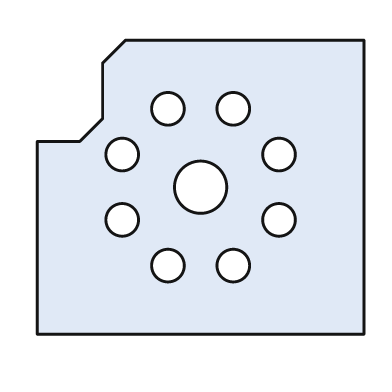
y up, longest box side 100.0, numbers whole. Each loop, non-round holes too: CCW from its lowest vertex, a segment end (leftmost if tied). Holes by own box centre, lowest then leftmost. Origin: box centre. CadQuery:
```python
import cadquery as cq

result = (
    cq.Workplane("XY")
    .moveTo(-50.0, -45.0)
    .lineTo(50.0, -45.0)
    .lineTo(50.0, 45.0)
    .lineTo(-23.0, 45.0)
    .lineTo(-30.0, 38.0)
    .lineTo(-30.0, 21.0)
    .lineTo(-37.0, 14.0)
    .lineTo(-50.0, 14.0)
    .close()
    .moveTo(-10.0, -24.0)
    .circle(5.0)
    .moveTo(10.0, -24.0)
    .circle(5.0)
    .moveTo(-24.0, -10.0)
    .circle(5.0)
    .moveTo(24.0, -10.0)
    .circle(5.0)
    .moveTo(0.0, 0.0)
    .circle(8.0)
    .moveTo(-24.0, 10.0)
    .circle(5.0)
    .moveTo(24.0, 10.0)
    .circle(5.0)
    .moveTo(-10.0, 24.0)
    .circle(5.0)
    .moveTo(10.0, 24.0)
    .circle(5.0)
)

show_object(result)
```